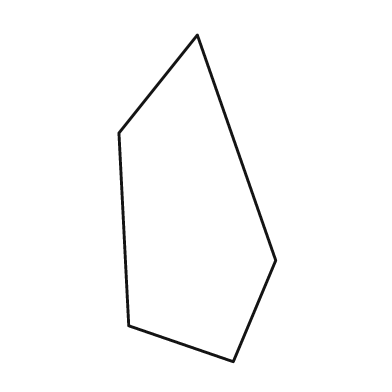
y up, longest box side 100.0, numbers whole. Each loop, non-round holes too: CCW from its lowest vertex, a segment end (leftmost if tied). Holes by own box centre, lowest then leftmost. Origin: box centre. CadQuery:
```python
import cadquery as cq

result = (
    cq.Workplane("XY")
    .moveTo(11.0, -50.0)
    .lineTo(24.0, -19.0)
    .lineTo(0.0, 50.0)
    .lineTo(-24.0, 20.0)
    .lineTo(-21.0, -39.0)
    .close()
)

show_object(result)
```